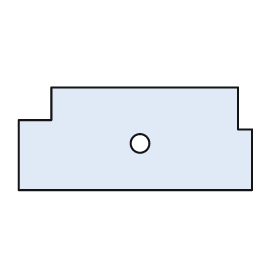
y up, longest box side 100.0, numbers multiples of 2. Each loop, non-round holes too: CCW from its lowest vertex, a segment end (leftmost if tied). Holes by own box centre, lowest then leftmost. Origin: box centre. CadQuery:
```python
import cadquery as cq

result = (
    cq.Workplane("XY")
    .moveTo(-50.0, -22.0)
    .lineTo(50.0, -22.0)
    .lineTo(50.0, 4.0)
    .lineTo(44.0, 4.0)
    .lineTo(44.0, 22.0)
    .lineTo(-36.0, 22.0)
    .lineTo(-36.0, 8.0)
    .lineTo(-50.0, 8.0)
    .close()
    .moveTo(2.0, -2.0)
    .circle(4.0)
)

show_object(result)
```